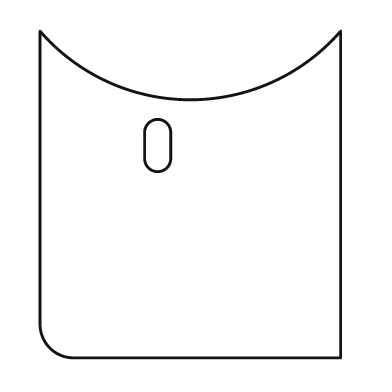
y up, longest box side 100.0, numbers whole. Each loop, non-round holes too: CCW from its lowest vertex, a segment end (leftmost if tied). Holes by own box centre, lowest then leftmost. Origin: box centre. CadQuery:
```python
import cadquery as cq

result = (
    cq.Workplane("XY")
    .moveTo(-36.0, -50.0)
    .lineTo(46.0, -50.0)
    .lineTo(46.0, 50.0)
    .threePointArc((0.0, 29.0), (-46.0, 50.0))
    .lineTo(-46.0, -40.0)
    .threePointArc((-43.0, -47.0), (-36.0, -50.0))
    .close()
    .moveTo(-14.0, 11.0)
    .threePointArc((-10.0, 7.0), (-6.0, 11.0))
    .lineTo(-6.0, 19.0)
    .threePointArc((-10.0, 23.0), (-14.0, 19.0))
    .close()
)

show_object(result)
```